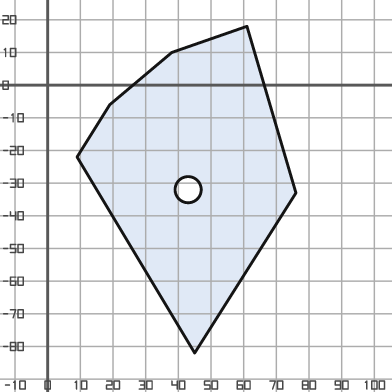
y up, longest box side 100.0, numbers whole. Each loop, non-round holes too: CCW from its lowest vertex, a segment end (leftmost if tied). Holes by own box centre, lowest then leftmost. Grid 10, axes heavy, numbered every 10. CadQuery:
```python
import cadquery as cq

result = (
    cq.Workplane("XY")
    .moveTo(45.0, -82.0)
    .lineTo(76.0, -33.0)
    .lineTo(61.0, 18.0)
    .lineTo(38.0, 10.0)
    .lineTo(19.0, -6.0)
    .lineTo(9.0, -22.0)
    .close()
    .moveTo(43.0, -32.0)
    .circle(4.0)
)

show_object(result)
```